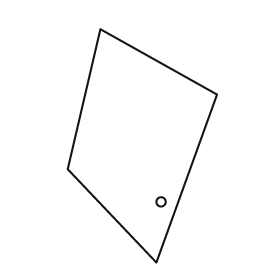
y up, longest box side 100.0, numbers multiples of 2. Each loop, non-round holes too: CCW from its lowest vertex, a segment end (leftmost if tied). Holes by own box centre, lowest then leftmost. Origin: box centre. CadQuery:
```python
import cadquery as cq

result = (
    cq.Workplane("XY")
    .moveTo(6.0, -50.0)
    .lineTo(32.0, 22.0)
    .lineTo(-18.0, 50.0)
    .lineTo(-32.0, -10.0)
    .close()
    .moveTo(8.0, -24.0)
    .circle(2.0)
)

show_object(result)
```